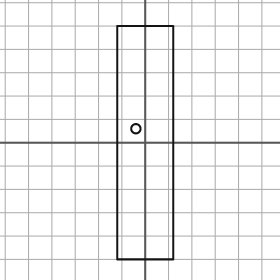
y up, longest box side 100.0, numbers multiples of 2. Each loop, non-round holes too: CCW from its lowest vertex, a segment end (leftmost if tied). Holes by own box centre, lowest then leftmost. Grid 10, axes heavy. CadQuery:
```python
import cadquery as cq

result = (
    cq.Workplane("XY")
    .moveTo(-12.0, -50.0)
    .lineTo(12.0, -50.0)
    .lineTo(12.0, 50.0)
    .lineTo(-12.0, 50.0)
    .close()
    .moveTo(-4.0, 6.0)
    .circle(2.0)
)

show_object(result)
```